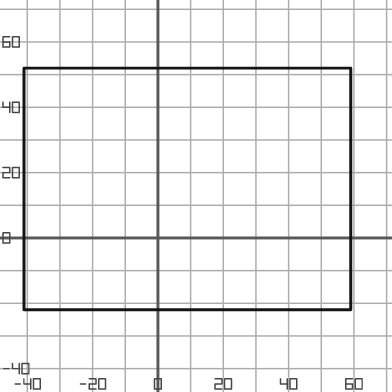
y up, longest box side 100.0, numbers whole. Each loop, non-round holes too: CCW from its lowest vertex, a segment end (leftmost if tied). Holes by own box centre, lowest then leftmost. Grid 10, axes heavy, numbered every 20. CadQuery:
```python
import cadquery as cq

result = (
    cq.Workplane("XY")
    .moveTo(-41.0, -22.0)
    .lineTo(59.0, -22.0)
    .lineTo(59.0, 52.0)
    .lineTo(-41.0, 52.0)
    .close()
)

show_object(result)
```